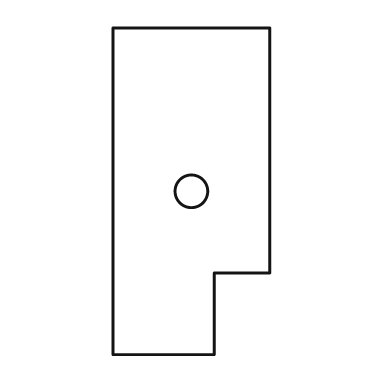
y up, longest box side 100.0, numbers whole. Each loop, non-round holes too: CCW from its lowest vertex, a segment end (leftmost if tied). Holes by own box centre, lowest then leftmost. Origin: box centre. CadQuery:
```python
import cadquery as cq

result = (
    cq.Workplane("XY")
    .moveTo(-24.0, -50.0)
    .lineTo(7.0, -50.0)
    .lineTo(7.0, -25.0)
    .lineTo(24.0, -25.0)
    .lineTo(24.0, 50.0)
    .lineTo(-24.0, 50.0)
    .close()
    .moveTo(0.0, 0.0)
    .circle(5.0)
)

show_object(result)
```